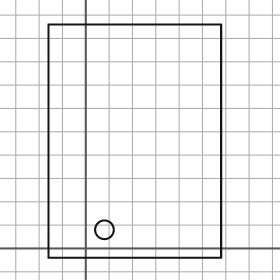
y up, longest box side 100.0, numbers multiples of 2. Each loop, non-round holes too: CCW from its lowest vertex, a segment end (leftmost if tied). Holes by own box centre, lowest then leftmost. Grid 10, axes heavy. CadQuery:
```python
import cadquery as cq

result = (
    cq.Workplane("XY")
    .moveTo(-16.0, -4.0)
    .lineTo(58.0, -4.0)
    .lineTo(58.0, 96.0)
    .lineTo(-16.0, 96.0)
    .close()
    .moveTo(8.0, 8.0)
    .circle(4.0)
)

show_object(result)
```